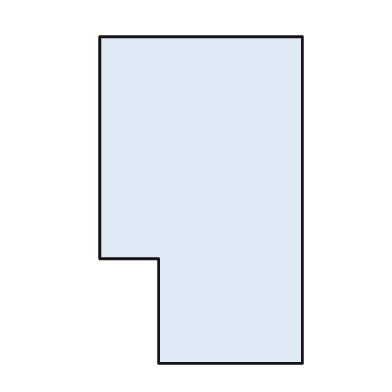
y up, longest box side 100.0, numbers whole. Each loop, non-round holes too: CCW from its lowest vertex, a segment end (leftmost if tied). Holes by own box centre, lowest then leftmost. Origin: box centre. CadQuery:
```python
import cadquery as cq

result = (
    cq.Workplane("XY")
    .moveTo(-13.0, -50.0)
    .lineTo(31.0, -50.0)
    .lineTo(31.0, 50.0)
    .lineTo(-31.0, 50.0)
    .lineTo(-31.0, -18.0)
    .lineTo(-13.0, -18.0)
    .close()
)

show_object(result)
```